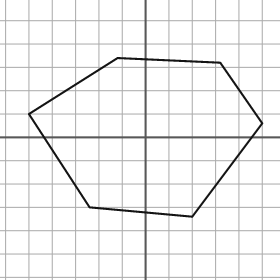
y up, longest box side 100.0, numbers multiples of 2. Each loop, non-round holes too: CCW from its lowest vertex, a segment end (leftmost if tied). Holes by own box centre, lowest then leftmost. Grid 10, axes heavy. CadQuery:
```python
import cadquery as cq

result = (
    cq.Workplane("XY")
    .moveTo(20.0, -34.0)
    .lineTo(50.0, 6.0)
    .lineTo(32.0, 32.0)
    .lineTo(-12.0, 34.0)
    .lineTo(-50.0, 10.0)
    .lineTo(-24.0, -30.0)
    .close()
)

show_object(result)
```